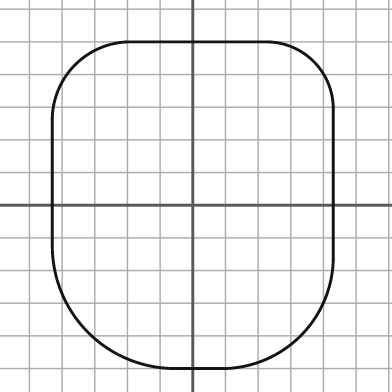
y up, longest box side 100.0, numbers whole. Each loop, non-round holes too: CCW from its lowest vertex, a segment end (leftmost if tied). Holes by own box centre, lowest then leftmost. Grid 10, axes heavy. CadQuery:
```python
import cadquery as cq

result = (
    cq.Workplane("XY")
    .moveTo(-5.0, -50.0)
    .lineTo(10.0, -50.0)
    .threePointArc((33.0, -40.0), (43.0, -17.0))
    .lineTo(43.0, 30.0)
    .threePointArc((37.0, 44.0), (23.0, 50.0))
    .lineTo(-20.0, 50.0)
    .threePointArc((-36.0, 43.0), (-43.0, 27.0))
    .lineTo(-43.0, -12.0)
    .threePointArc((-32.0, -39.0), (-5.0, -50.0))
    .close()
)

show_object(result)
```